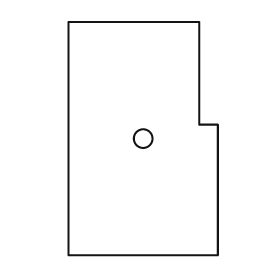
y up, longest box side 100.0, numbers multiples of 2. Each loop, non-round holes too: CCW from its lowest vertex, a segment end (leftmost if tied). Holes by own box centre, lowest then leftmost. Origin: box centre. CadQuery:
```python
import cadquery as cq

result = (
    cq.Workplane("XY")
    .moveTo(-32.0, -50.0)
    .lineTo(32.0, -50.0)
    .lineTo(32.0, 6.0)
    .lineTo(24.0, 6.0)
    .lineTo(24.0, 50.0)
    .lineTo(-32.0, 50.0)
    .close()
    .moveTo(0.0, 0.0)
    .circle(4.0)
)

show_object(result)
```